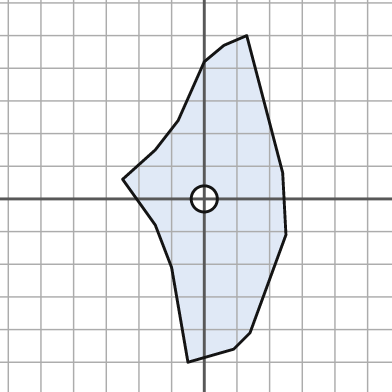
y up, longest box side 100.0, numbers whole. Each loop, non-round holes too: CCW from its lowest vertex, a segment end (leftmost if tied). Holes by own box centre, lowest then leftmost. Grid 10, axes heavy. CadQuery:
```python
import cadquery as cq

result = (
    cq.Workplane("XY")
    .moveTo(-5.0, -50.0)
    .lineTo(9.0, -46.0)
    .lineTo(14.0, -41.0)
    .lineTo(25.0, -11.0)
    .lineTo(24.0, 8.0)
    .lineTo(13.0, 50.0)
    .lineTo(6.0, 47.0)
    .lineTo(0.0, 42.0)
    .lineTo(-8.0, 24.0)
    .lineTo(-15.0, 15.0)
    .lineTo(-25.0, 6.0)
    .lineTo(-15.0, -8.0)
    .lineTo(-10.0, -21.0)
    .close()
    .moveTo(0.0, 0.0)
    .circle(4.0)
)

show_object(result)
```